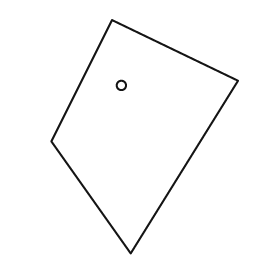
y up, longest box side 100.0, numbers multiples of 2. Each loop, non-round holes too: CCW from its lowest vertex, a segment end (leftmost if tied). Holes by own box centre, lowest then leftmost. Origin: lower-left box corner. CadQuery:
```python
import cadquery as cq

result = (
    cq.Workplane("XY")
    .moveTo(34.0, 0.0)
    .lineTo(80.0, 74.0)
    .lineTo(26.0, 100.0)
    .lineTo(0.0, 48.0)
    .close()
    .moveTo(30.0, 72.0)
    .circle(2.0)
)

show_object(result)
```